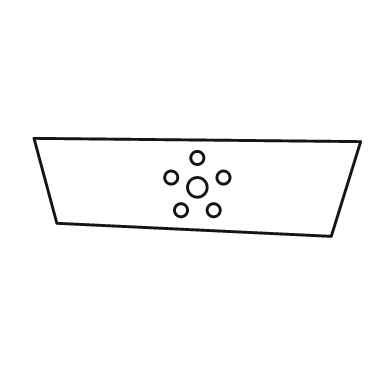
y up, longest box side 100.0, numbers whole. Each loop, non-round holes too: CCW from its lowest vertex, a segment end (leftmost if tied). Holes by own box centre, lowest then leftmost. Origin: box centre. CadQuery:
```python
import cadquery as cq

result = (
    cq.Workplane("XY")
    .moveTo(41.0, -15.0)
    .lineTo(50.0, 14.0)
    .lineTo(-50.0, 15.0)
    .lineTo(-43.0, -11.0)
    .close()
    .moveTo(-5.0, -7.0)
    .circle(2.0)
    .moveTo(5.0, -7.0)
    .circle(2.0)
    .moveTo(0.0, 0.0)
    .circle(3.0)
    .moveTo(-8.0, 3.0)
    .circle(2.0)
    .moveTo(8.0, 3.0)
    .circle(2.0)
    .moveTo(0.0, 9.0)
    .circle(2.0)
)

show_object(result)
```